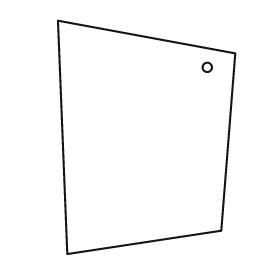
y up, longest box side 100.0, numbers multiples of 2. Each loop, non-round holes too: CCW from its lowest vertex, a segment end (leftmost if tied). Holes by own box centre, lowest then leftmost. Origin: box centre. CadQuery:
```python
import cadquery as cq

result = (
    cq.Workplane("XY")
    .moveTo(-34.0, -50.0)
    .lineTo(32.0, -40.0)
    .lineTo(38.0, 36.0)
    .lineTo(-38.0, 50.0)
    .close()
    .moveTo(26.0, 30.0)
    .circle(2.0)
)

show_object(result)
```